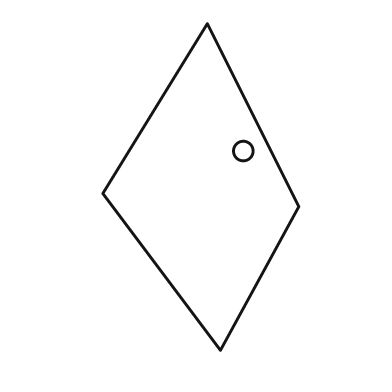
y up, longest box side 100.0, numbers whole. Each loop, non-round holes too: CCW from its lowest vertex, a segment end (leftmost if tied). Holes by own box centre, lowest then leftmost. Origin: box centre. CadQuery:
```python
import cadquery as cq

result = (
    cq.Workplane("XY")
    .moveTo(6.0, -50.0)
    .lineTo(30.0, -6.0)
    .lineTo(2.0, 50.0)
    .lineTo(-30.0, -2.0)
    .close()
    .moveTo(13.0, 11.0)
    .circle(3.0)
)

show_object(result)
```